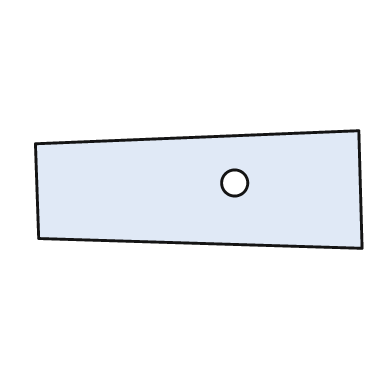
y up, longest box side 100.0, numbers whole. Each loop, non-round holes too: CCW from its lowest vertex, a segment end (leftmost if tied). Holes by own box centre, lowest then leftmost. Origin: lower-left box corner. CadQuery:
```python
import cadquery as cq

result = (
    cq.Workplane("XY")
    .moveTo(100.0, 0.0)
    .lineTo(99.0, 36.0)
    .lineTo(0.0, 32.0)
    .lineTo(1.0, 3.0)
    .close()
    .moveTo(61.0, 20.0)
    .circle(4.0)
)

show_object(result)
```